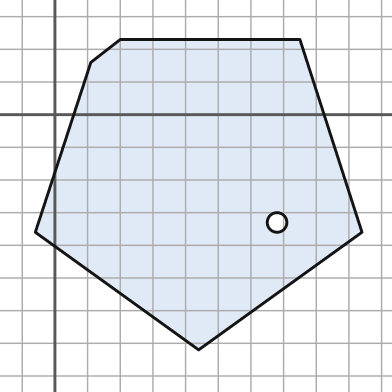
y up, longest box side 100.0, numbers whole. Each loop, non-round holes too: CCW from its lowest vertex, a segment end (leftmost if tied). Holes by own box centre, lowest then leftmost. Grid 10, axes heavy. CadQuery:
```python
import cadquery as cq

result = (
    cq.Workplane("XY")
    .moveTo(44.0, -72.0)
    .lineTo(94.0, -36.0)
    .lineTo(75.0, 23.0)
    .lineTo(20.0, 23.0)
    .lineTo(11.0, 16.0)
    .lineTo(-6.0, -36.0)
    .close()
    .moveTo(68.0, -33.0)
    .circle(3.0)
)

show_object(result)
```